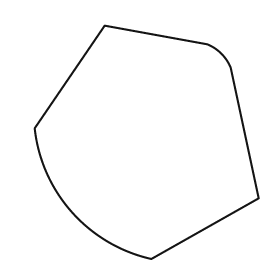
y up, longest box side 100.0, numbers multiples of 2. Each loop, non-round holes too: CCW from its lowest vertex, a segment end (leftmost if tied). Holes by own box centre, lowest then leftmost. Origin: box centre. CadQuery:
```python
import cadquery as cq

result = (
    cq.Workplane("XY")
    .moveTo(2.0, -50.0)
    .lineTo(48.0, -24.0)
    .lineTo(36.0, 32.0)
    .threePointArc((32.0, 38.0), (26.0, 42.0))
    .lineTo(-18.0, 50.0)
    .lineTo(-48.0, 6.0)
    .threePointArc((-32.0, -30.0), (2.0, -50.0))
    .close()
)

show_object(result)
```